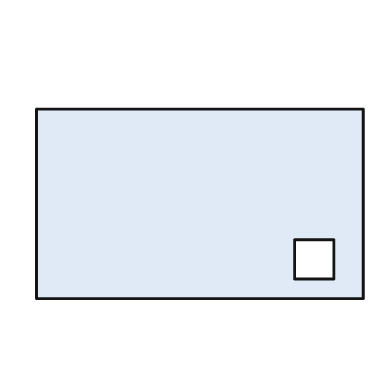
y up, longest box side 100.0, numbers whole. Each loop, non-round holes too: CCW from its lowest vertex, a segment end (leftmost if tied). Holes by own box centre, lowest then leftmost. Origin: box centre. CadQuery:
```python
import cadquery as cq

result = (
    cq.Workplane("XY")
    .moveTo(-50.0, -29.0)
    .lineTo(50.0, -29.0)
    .lineTo(50.0, 29.0)
    .lineTo(-50.0, 29.0)
    .close()
    .moveTo(29.0, -23.0)
    .lineTo(41.0, -23.0)
    .lineTo(41.0, -11.0)
    .lineTo(29.0, -11.0)
    .close()
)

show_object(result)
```